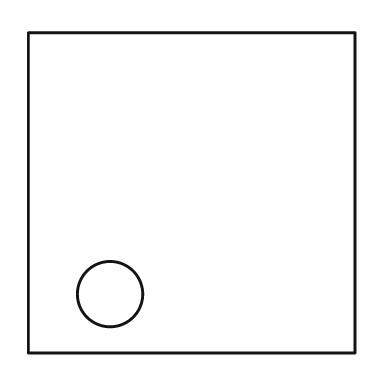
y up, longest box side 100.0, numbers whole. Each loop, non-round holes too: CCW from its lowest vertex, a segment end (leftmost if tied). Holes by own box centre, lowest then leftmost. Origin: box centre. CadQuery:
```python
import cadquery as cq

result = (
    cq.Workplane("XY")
    .moveTo(-50.0, -49.0)
    .lineTo(50.0, -49.0)
    .lineTo(50.0, 49.0)
    .lineTo(-50.0, 49.0)
    .close()
    .moveTo(-25.0, -31.0)
    .circle(10.0)
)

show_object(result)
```